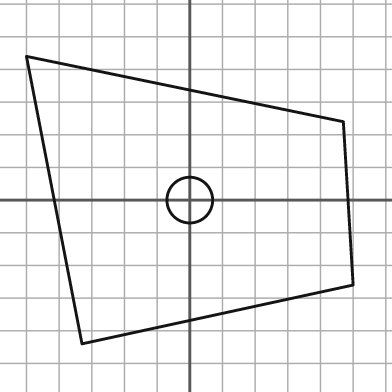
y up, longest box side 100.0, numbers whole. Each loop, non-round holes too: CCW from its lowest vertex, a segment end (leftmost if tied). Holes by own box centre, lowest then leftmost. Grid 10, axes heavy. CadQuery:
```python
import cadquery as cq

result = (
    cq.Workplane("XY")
    .moveTo(-33.0, -44.0)
    .lineTo(50.0, -26.0)
    .lineTo(47.0, 24.0)
    .lineTo(-50.0, 44.0)
    .close()
    .moveTo(0.0, 0.0)
    .circle(7.0)
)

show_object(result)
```